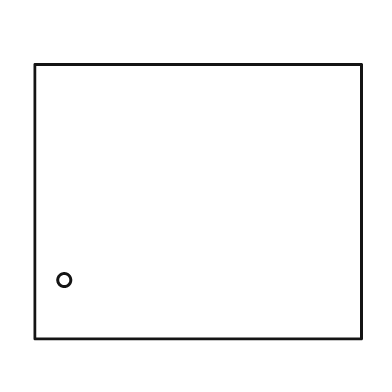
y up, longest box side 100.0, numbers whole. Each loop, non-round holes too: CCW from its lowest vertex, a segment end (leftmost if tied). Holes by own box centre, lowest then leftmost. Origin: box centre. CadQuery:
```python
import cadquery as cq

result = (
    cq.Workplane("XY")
    .moveTo(-50.0, -42.0)
    .lineTo(50.0, -42.0)
    .lineTo(50.0, 42.0)
    .lineTo(-50.0, 42.0)
    .close()
    .moveTo(-41.0, -24.0)
    .circle(2.0)
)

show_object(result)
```